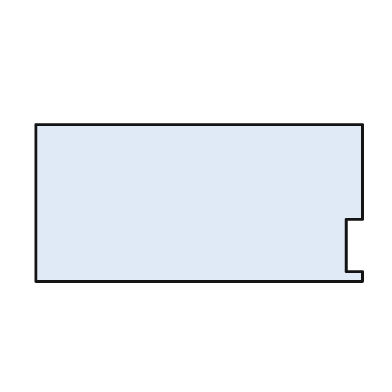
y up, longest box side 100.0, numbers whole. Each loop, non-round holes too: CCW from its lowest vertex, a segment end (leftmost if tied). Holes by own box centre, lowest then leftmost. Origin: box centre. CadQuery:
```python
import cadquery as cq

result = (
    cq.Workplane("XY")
    .moveTo(-50.0, -24.0)
    .lineTo(50.0, -24.0)
    .lineTo(50.0, -21.0)
    .lineTo(45.0, -21.0)
    .lineTo(45.0, -5.0)
    .lineTo(50.0, -5.0)
    .lineTo(50.0, 24.0)
    .lineTo(-50.0, 24.0)
    .close()
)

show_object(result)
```